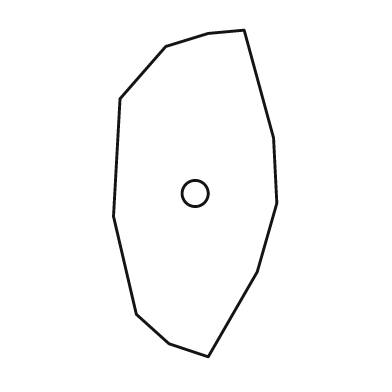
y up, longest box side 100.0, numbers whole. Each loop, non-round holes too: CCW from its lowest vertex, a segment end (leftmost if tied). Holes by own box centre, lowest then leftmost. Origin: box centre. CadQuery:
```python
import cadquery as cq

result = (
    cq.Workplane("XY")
    .moveTo(4.0, -50.0)
    .lineTo(19.0, -24.0)
    .lineTo(25.0, -3.0)
    .lineTo(24.0, 17.0)
    .lineTo(15.0, 50.0)
    .lineTo(4.0, 49.0)
    .lineTo(-9.0, 45.0)
    .lineTo(-23.0, 29.0)
    .lineTo(-25.0, -7.0)
    .lineTo(-18.0, -37.0)
    .lineTo(-8.0, -46.0)
    .close()
    .moveTo(0.0, 0.0)
    .circle(4.0)
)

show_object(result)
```